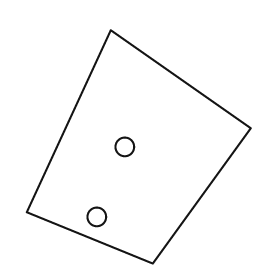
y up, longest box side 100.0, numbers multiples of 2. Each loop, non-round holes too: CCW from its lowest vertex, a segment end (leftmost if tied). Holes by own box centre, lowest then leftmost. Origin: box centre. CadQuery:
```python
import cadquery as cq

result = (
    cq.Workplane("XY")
    .moveTo(6.0, -50.0)
    .lineTo(48.0, 8.0)
    .lineTo(-12.0, 50.0)
    .lineTo(-48.0, -28.0)
    .close()
    .moveTo(-18.0, -30.0)
    .circle(4.0)
    .moveTo(-6.0, 0.0)
    .circle(4.0)
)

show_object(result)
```